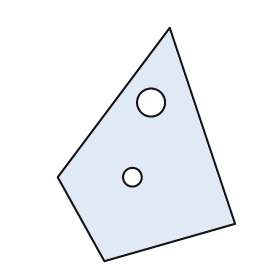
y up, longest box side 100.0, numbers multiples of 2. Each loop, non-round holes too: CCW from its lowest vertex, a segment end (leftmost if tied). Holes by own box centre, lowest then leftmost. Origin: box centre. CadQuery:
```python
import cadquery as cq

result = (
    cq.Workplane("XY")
    .moveTo(-18.0, -50.0)
    .lineTo(38.0, -34.0)
    .lineTo(10.0, 50.0)
    .lineTo(-38.0, -14.0)
    .close()
    .moveTo(-6.0, -14.0)
    .circle(4.0)
    .moveTo(2.0, 18.0)
    .circle(6.0)
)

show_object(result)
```